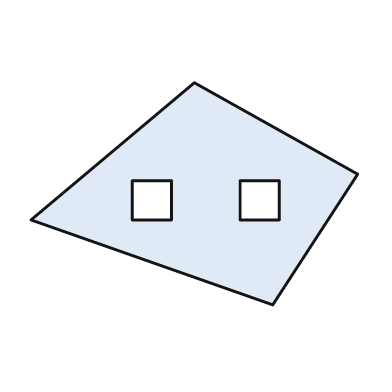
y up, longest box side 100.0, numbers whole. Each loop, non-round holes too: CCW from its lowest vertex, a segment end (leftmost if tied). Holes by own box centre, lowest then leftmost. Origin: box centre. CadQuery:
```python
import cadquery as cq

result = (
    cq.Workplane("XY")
    .moveTo(24.0, -34.0)
    .lineTo(50.0, 6.0)
    .lineTo(0.0, 34.0)
    .lineTo(-50.0, -8.0)
    .close()
    .moveTo(-19.0, -8.0)
    .lineTo(-7.0, -8.0)
    .lineTo(-7.0, 4.0)
    .lineTo(-19.0, 4.0)
    .close()
    .moveTo(14.0, -8.0)
    .lineTo(26.0, -8.0)
    .lineTo(26.0, 4.0)
    .lineTo(14.0, 4.0)
    .close()
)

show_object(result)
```